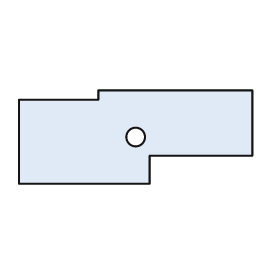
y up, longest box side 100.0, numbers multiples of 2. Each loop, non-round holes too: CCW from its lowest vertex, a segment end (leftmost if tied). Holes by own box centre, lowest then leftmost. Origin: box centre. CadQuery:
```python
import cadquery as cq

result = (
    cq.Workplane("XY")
    .moveTo(-50.0, -20.0)
    .lineTo(6.0, -20.0)
    .lineTo(6.0, -8.0)
    .lineTo(50.0, -8.0)
    .lineTo(50.0, 20.0)
    .lineTo(-16.0, 20.0)
    .lineTo(-16.0, 16.0)
    .lineTo(-50.0, 16.0)
    .close()
    .moveTo(0.0, 0.0)
    .circle(4.0)
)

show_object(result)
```